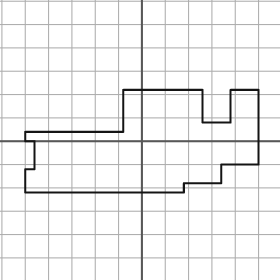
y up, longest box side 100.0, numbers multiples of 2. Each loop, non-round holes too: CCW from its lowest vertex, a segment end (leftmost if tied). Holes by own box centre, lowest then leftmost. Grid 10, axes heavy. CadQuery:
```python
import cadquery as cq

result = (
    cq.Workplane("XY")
    .moveTo(-50.0, -22.0)
    .lineTo(18.0, -22.0)
    .lineTo(18.0, -18.0)
    .lineTo(34.0, -18.0)
    .lineTo(34.0, -10.0)
    .lineTo(50.0, -10.0)
    .lineTo(50.0, 22.0)
    .lineTo(38.0, 22.0)
    .lineTo(38.0, 8.0)
    .lineTo(26.0, 8.0)
    .lineTo(26.0, 22.0)
    .lineTo(-8.0, 22.0)
    .lineTo(-8.0, 4.0)
    .lineTo(-50.0, 4.0)
    .lineTo(-50.0, 0.0)
    .lineTo(-46.0, 0.0)
    .lineTo(-46.0, -12.0)
    .lineTo(-50.0, -12.0)
    .close()
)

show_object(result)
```